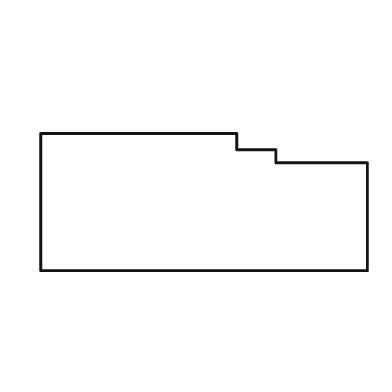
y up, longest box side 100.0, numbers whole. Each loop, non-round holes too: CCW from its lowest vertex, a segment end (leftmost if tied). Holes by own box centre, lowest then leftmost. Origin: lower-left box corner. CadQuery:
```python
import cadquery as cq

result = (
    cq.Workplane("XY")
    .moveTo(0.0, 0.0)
    .lineTo(100.0, 0.0)
    .lineTo(100.0, 33.0)
    .lineTo(72.0, 33.0)
    .lineTo(72.0, 37.0)
    .lineTo(60.0, 37.0)
    .lineTo(60.0, 42.0)
    .lineTo(0.0, 42.0)
    .close()
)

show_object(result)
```